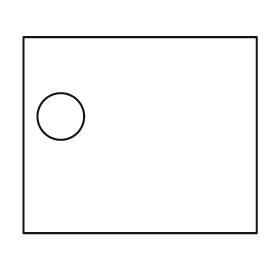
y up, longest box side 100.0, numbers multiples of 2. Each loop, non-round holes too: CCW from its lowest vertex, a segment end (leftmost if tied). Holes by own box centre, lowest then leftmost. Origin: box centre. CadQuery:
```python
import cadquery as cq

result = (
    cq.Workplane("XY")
    .moveTo(-50.0, -42.0)
    .lineTo(50.0, -42.0)
    .lineTo(50.0, 42.0)
    .lineTo(-50.0, 42.0)
    .close()
    .moveTo(-34.0, 8.0)
    .circle(10.0)
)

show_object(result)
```